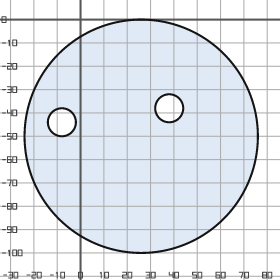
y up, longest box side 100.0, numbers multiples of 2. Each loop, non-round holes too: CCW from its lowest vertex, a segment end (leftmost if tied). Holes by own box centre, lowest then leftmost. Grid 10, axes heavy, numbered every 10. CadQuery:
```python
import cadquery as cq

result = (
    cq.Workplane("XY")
    .moveTo(26.0, -50.0)
    .circle(50.0)
    .moveTo(-8.0, -44.0)
    .circle(6.0)
    .moveTo(38.0, -38.0)
    .circle(6.0)
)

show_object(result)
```